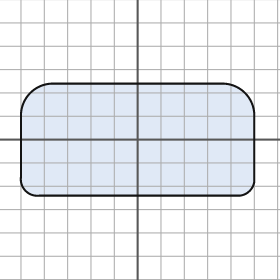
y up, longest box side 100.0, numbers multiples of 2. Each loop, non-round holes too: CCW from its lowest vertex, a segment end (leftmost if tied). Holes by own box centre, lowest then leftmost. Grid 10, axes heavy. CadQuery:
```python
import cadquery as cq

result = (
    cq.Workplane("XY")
    .moveTo(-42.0, -24.0)
    .lineTo(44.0, -24.0)
    .threePointArc((48.0, -22.0), (50.0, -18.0))
    .lineTo(50.0, 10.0)
    .threePointArc((46.0, 20.0), (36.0, 24.0))
    .lineTo(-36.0, 24.0)
    .threePointArc((-46.0, 20.0), (-50.0, 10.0))
    .lineTo(-50.0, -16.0)
    .threePointArc((-48.0, -22.0), (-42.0, -24.0))
    .close()
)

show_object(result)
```